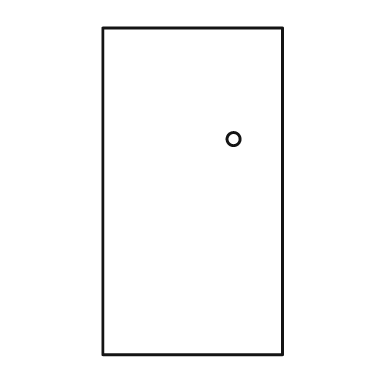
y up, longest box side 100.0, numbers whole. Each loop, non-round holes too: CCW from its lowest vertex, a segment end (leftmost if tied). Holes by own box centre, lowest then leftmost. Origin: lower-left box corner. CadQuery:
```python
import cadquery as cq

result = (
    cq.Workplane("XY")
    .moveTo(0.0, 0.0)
    .lineTo(55.0, 0.0)
    .lineTo(55.0, 100.0)
    .lineTo(0.0, 100.0)
    .close()
    .moveTo(40.0, 66.0)
    .circle(2.0)
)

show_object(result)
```